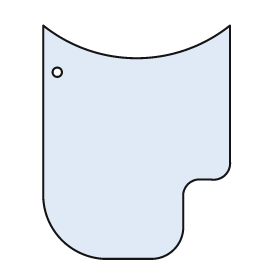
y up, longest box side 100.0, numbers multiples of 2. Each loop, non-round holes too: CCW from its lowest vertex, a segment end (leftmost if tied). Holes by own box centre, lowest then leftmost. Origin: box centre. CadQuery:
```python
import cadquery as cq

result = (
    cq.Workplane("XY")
    .moveTo(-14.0, -50.0)
    .lineTo(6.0, -50.0)
    .threePointArc((16.0, -46.0), (20.0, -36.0))
    .lineTo(20.0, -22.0)
    .threePointArc((22.0, -18.0), (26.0, -16.0))
    .lineTo(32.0, -16.0)
    .threePointArc((38.0, -14.0), (40.0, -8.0))
    .lineTo(40.0, 50.0)
    .threePointArc((0.0, 36.0), (-40.0, 50.0))
    .lineTo(-40.0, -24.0)
    .threePointArc((-32.0, -42.0), (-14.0, -50.0))
    .close()
    .moveTo(-34.0, 30.0)
    .circle(2.0)
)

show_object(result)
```